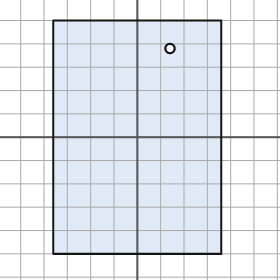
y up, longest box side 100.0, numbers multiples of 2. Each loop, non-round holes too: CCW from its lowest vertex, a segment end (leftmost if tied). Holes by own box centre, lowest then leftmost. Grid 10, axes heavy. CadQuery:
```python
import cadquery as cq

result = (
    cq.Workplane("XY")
    .moveTo(-36.0, -50.0)
    .lineTo(36.0, -50.0)
    .lineTo(36.0, 50.0)
    .lineTo(-36.0, 50.0)
    .close()
    .moveTo(14.0, 38.0)
    .circle(2.0)
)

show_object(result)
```